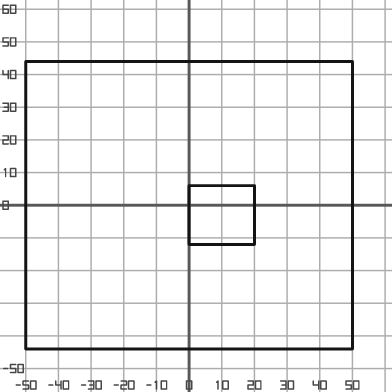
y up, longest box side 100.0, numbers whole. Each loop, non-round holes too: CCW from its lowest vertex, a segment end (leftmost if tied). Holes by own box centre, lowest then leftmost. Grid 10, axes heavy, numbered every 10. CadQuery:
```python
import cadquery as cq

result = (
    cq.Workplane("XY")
    .moveTo(-50.0, -44.0)
    .lineTo(50.0, -44.0)
    .lineTo(50.0, 44.0)
    .lineTo(-50.0, 44.0)
    .close()
    .moveTo(0.0, -12.0)
    .lineTo(20.0, -12.0)
    .lineTo(20.0, 6.0)
    .lineTo(0.0, 6.0)
    .close()
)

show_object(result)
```